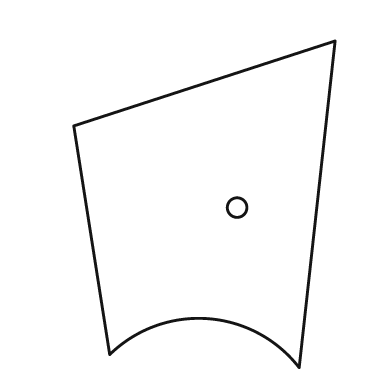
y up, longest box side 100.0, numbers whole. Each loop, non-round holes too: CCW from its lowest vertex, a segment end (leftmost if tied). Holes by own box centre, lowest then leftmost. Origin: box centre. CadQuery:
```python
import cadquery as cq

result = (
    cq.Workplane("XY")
    .moveTo(29.0, -50.0)
    .lineTo(40.0, 50.0)
    .lineTo(-40.0, 24.0)
    .lineTo(-29.0, -46.0)
    .threePointArc((1.0, -35.0), (29.0, -50.0))
    .close()
    .moveTo(10.0, -1.0)
    .circle(3.0)
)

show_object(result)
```